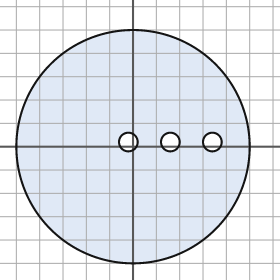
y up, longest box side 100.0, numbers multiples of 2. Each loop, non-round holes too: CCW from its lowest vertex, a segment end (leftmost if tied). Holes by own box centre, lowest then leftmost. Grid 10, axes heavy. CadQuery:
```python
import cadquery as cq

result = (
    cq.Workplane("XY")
    .moveTo(0.0, 0.0)
    .circle(50.0)
    .moveTo(-2.0, 2.0)
    .circle(4.0)
    .moveTo(16.0, 2.0)
    .circle(4.0)
    .moveTo(34.0, 2.0)
    .circle(4.0)
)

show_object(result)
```